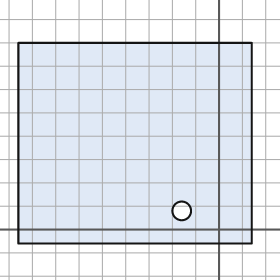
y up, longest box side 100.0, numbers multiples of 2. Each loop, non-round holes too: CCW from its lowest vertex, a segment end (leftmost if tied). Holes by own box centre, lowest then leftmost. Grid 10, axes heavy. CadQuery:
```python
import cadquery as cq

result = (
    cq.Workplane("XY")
    .moveTo(-86.0, -6.0)
    .lineTo(14.0, -6.0)
    .lineTo(14.0, 80.0)
    .lineTo(-86.0, 80.0)
    .close()
    .moveTo(-16.0, 8.0)
    .circle(4.0)
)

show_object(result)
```